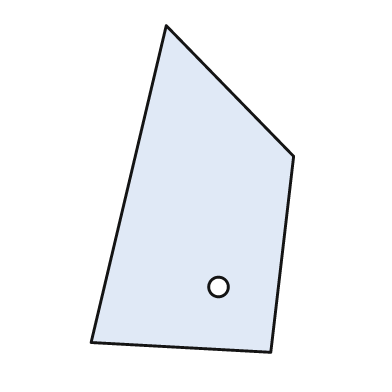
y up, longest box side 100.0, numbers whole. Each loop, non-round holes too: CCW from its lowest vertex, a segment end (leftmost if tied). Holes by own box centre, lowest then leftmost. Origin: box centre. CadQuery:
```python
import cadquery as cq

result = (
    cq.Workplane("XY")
    .moveTo(24.0, -50.0)
    .lineTo(31.0, 10.0)
    .lineTo(-8.0, 50.0)
    .lineTo(-31.0, -47.0)
    .close()
    .moveTo(8.0, -30.0)
    .circle(3.0)
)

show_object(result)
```